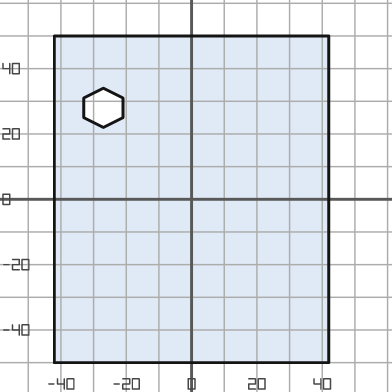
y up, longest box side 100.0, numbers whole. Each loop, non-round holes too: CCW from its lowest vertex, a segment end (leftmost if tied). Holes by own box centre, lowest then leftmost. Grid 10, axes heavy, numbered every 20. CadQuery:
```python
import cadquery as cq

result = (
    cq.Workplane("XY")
    .moveTo(-42.0, -50.0)
    .lineTo(42.0, -50.0)
    .lineTo(42.0, 50.0)
    .lineTo(-42.0, 50.0)
    .close()
    .moveTo(-27.0, 22.0)
    .lineTo(-21.0, 25.0)
    .lineTo(-21.0, 31.0)
    .lineTo(-27.0, 34.0)
    .lineTo(-33.0, 31.0)
    .lineTo(-33.0, 25.0)
    .close()
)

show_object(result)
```